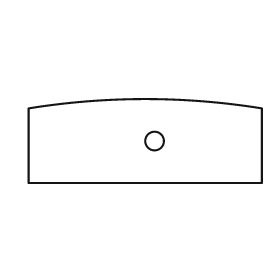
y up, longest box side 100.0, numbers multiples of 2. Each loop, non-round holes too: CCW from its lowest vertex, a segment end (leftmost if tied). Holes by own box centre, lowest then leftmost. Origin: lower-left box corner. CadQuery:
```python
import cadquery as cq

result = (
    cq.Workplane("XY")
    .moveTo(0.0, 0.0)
    .lineTo(100.0, 0.0)
    .lineTo(100.0, 32.0)
    .threePointArc((50.0, 36.0), (0.0, 32.0))
    .close()
    .moveTo(54.0, 18.0)
    .circle(4.0)
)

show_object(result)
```